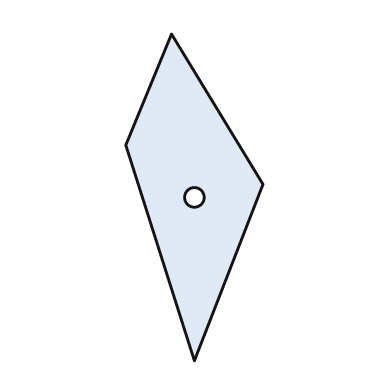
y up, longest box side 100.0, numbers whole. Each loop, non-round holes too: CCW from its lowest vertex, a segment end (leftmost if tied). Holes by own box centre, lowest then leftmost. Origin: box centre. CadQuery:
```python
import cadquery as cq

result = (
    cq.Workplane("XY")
    .moveTo(0.0, -50.0)
    .lineTo(21.0, 4.0)
    .lineTo(-7.0, 50.0)
    .lineTo(-21.0, 16.0)
    .close()
    .moveTo(0.0, 0.0)
    .circle(3.0)
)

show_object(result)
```